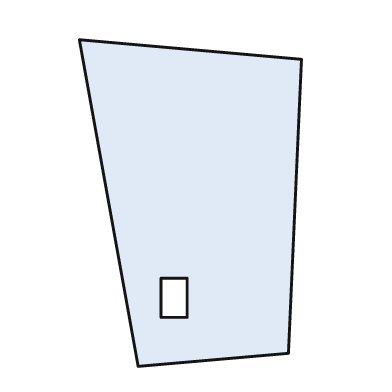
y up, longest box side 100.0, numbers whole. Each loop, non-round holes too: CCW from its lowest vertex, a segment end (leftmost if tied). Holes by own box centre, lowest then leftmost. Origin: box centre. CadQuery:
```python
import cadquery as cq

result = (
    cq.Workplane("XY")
    .moveTo(-16.0, -50.0)
    .lineTo(30.0, -46.0)
    .lineTo(34.0, 44.0)
    .lineTo(-34.0, 50.0)
    .close()
    .moveTo(-9.0, -35.0)
    .lineTo(-1.0, -35.0)
    .lineTo(-1.0, -23.0)
    .lineTo(-9.0, -23.0)
    .close()
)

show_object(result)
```